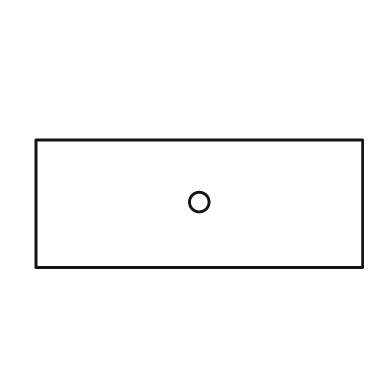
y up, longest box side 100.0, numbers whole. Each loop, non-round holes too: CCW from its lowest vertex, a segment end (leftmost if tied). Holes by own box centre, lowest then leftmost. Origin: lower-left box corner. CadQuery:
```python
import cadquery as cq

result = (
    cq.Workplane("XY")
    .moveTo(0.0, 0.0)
    .lineTo(100.0, 0.0)
    .lineTo(100.0, 39.0)
    .lineTo(0.0, 39.0)
    .close()
    .moveTo(50.0, 20.0)
    .circle(3.0)
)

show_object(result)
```